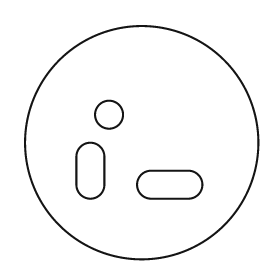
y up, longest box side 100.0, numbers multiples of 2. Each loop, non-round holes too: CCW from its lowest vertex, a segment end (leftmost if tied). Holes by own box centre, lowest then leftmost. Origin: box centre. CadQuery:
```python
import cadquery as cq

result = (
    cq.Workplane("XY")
    .moveTo(0.0, 0.0)
    .circle(50.0)
    .moveTo(4.0, -24.0)
    .lineTo(20.0, -24.0)
    .threePointArc((26.0, -18.0), (20.0, -12.0))
    .lineTo(4.0, -12.0)
    .threePointArc((-2.0, -18.0), (4.0, -24.0))
    .close()
    .moveTo(-28.0, -18.0)
    .threePointArc((-22.0, -24.0), (-16.0, -18.0))
    .lineTo(-16.0, -6.0)
    .threePointArc((-22.0, 0.0), (-28.0, -6.0))
    .close()
    .moveTo(-14.0, 12.0)
    .circle(6.0)
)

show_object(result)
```